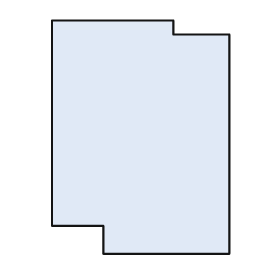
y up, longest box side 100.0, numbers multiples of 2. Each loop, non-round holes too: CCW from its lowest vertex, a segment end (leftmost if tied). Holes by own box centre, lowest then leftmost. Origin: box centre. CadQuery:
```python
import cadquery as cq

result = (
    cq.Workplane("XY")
    .moveTo(-16.0, -50.0)
    .lineTo(38.0, -50.0)
    .lineTo(38.0, 44.0)
    .lineTo(14.0, 44.0)
    .lineTo(14.0, 50.0)
    .lineTo(-38.0, 50.0)
    .lineTo(-38.0, -38.0)
    .lineTo(-16.0, -38.0)
    .close()
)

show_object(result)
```